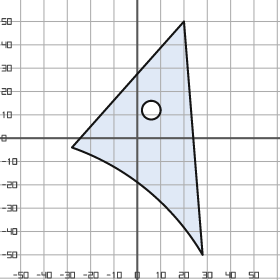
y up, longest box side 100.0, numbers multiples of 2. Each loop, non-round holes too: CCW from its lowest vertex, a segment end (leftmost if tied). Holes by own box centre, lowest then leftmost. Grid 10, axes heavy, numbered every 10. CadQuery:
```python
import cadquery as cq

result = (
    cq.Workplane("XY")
    .moveTo(28.0, -50.0)
    .lineTo(20.0, 50.0)
    .lineTo(-28.0, -4.0)
    .threePointArc((4.0, -22.0), (28.0, -50.0))
    .close()
    .moveTo(6.0, 12.0)
    .circle(4.0)
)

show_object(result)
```